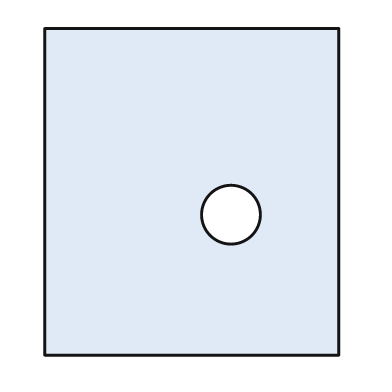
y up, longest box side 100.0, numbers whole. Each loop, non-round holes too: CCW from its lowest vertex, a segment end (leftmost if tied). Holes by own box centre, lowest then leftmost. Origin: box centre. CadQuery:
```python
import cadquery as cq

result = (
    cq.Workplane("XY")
    .moveTo(-45.0, -50.0)
    .lineTo(45.0, -50.0)
    .lineTo(45.0, 50.0)
    .lineTo(-45.0, 50.0)
    .close()
    .moveTo(12.0, -7.0)
    .circle(9.0)
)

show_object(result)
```